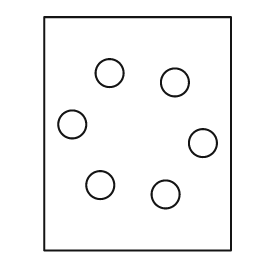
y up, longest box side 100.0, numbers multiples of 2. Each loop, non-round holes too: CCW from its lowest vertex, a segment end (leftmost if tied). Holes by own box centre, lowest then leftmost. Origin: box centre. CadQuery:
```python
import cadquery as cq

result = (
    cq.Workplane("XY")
    .moveTo(-40.0, -50.0)
    .lineTo(40.0, -50.0)
    .lineTo(40.0, 50.0)
    .lineTo(-40.0, 50.0)
    .close()
    .moveTo(12.0, -26.0)
    .circle(6.0)
    .moveTo(-16.0, -22.0)
    .circle(6.0)
    .moveTo(28.0, -4.0)
    .circle(6.0)
    .moveTo(-28.0, 4.0)
    .circle(6.0)
    .moveTo(16.0, 22.0)
    .circle(6.0)
    .moveTo(-12.0, 26.0)
    .circle(6.0)
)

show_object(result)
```